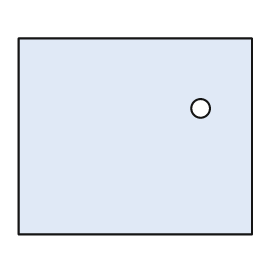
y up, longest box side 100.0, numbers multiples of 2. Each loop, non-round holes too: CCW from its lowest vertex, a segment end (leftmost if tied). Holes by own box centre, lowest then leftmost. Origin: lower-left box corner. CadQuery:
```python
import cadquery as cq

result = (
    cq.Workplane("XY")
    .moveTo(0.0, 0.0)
    .lineTo(100.0, 0.0)
    .lineTo(100.0, 84.0)
    .lineTo(0.0, 84.0)
    .close()
    .moveTo(78.0, 54.0)
    .circle(4.0)
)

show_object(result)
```